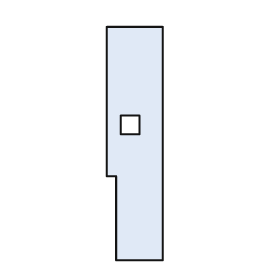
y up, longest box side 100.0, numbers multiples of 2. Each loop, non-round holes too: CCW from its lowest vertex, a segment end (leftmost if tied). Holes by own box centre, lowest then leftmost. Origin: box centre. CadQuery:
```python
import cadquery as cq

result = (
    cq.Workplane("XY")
    .moveTo(-8.0, -50.0)
    .lineTo(12.0, -50.0)
    .lineTo(12.0, 50.0)
    .lineTo(-12.0, 50.0)
    .lineTo(-12.0, -14.0)
    .lineTo(-8.0, -14.0)
    .close()
    .moveTo(-6.0, 4.0)
    .lineTo(2.0, 4.0)
    .lineTo(2.0, 12.0)
    .lineTo(-6.0, 12.0)
    .close()
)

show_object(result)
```